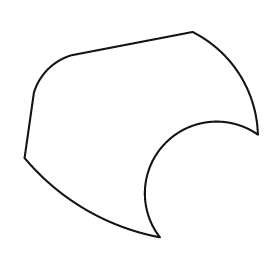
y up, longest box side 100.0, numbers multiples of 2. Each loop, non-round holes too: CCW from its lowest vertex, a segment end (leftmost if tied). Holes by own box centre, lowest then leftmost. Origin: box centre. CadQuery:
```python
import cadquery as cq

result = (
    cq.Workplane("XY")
    .moveTo(8.0, -44.0)
    .threePointArc((10.0, -4.0), (50.0, 0.0))
    .threePointArc((42.0, 26.0), (22.0, 44.0))
    .lineTo(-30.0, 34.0)
    .threePointArc((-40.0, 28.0), (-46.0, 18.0))
    .lineTo(-50.0, -10.0)
    .threePointArc((-24.0, -32.0), (8.0, -44.0))
    .close()
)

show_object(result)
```